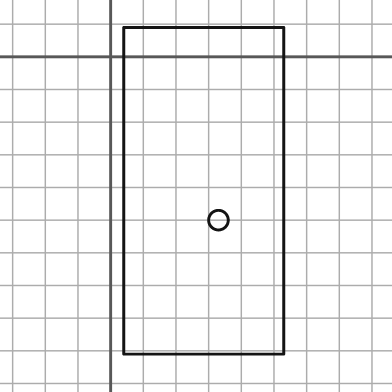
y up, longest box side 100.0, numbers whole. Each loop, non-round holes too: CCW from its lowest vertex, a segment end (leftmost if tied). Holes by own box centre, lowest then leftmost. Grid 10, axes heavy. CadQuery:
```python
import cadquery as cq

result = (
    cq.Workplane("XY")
    .moveTo(4.0, -91.0)
    .lineTo(53.0, -91.0)
    .lineTo(53.0, 9.0)
    .lineTo(4.0, 9.0)
    .close()
    .moveTo(33.0, -50.0)
    .circle(3.0)
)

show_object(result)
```